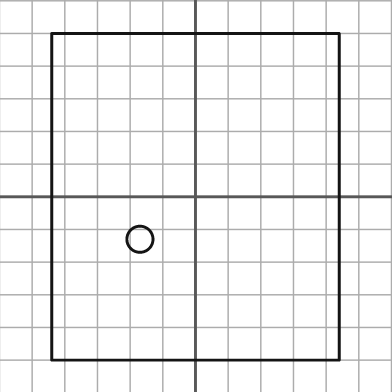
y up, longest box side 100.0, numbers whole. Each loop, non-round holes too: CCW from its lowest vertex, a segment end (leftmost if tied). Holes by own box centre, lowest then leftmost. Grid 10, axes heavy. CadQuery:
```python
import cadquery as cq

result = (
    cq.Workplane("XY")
    .moveTo(-44.0, -50.0)
    .lineTo(44.0, -50.0)
    .lineTo(44.0, 50.0)
    .lineTo(-44.0, 50.0)
    .close()
    .moveTo(-17.0, -13.0)
    .circle(4.0)
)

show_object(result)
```